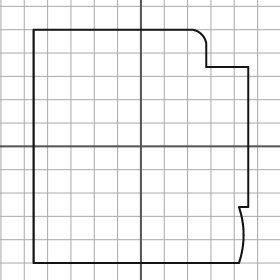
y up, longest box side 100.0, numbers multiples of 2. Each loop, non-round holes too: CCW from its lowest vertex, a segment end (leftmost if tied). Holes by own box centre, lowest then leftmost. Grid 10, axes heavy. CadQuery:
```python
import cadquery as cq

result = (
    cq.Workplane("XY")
    .moveTo(-46.0, -50.0)
    .lineTo(42.0, -50.0)
    .threePointArc((44.0, -38.0), (42.0, -26.0))
    .lineTo(46.0, -26.0)
    .lineTo(46.0, 34.0)
    .lineTo(28.0, 34.0)
    .lineTo(28.0, 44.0)
    .threePointArc((26.0, 48.0), (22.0, 50.0))
    .lineTo(-46.0, 50.0)
    .close()
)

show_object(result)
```